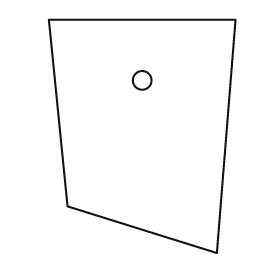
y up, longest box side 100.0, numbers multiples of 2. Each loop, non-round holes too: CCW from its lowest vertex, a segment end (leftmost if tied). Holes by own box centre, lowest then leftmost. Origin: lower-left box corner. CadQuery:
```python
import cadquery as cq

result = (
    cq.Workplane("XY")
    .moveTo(72.0, 0.0)
    .lineTo(80.0, 100.0)
    .lineTo(0.0, 100.0)
    .lineTo(8.0, 20.0)
    .close()
    .moveTo(40.0, 74.0)
    .circle(4.0)
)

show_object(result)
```